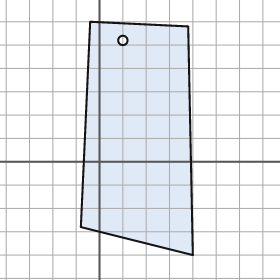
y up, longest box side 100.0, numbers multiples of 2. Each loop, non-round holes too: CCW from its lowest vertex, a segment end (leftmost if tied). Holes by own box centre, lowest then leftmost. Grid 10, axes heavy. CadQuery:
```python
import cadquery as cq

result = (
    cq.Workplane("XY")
    .moveTo(40.0, -40.0)
    .lineTo(38.0, 58.0)
    .lineTo(-4.0, 60.0)
    .lineTo(-8.0, -28.0)
    .close()
    .moveTo(10.0, 52.0)
    .circle(2.0)
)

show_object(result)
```